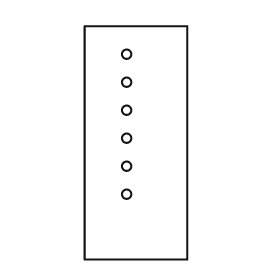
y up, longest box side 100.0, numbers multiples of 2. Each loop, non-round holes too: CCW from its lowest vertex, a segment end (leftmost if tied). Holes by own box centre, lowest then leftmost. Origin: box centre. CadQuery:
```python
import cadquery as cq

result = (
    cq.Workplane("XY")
    .moveTo(-22.0, -50.0)
    .lineTo(22.0, -50.0)
    .lineTo(22.0, 50.0)
    .lineTo(-22.0, 50.0)
    .close()
    .moveTo(-4.0, -22.0)
    .circle(2.0)
    .moveTo(-4.0, -10.0)
    .circle(2.0)
    .moveTo(-4.0, 2.0)
    .circle(2.0)
    .moveTo(-4.0, 14.0)
    .circle(2.0)
    .moveTo(-4.0, 26.0)
    .circle(2.0)
    .moveTo(-4.0, 38.0)
    .circle(2.0)
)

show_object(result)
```